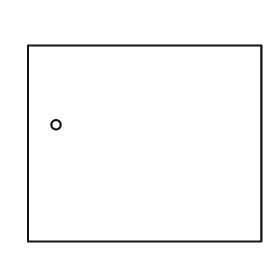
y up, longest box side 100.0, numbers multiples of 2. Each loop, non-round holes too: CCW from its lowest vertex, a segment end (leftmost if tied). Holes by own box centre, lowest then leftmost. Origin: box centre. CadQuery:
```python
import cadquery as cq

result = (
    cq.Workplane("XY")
    .moveTo(-50.0, -42.0)
    .lineTo(50.0, -42.0)
    .lineTo(50.0, 42.0)
    .lineTo(-50.0, 42.0)
    .close()
    .moveTo(-38.0, 8.0)
    .circle(2.0)
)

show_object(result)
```